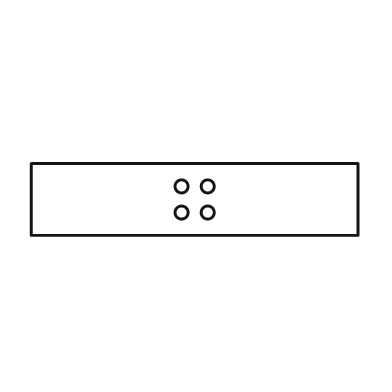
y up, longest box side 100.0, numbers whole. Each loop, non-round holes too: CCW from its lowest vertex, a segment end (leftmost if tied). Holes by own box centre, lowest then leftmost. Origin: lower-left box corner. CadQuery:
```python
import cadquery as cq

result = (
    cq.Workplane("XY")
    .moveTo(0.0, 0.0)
    .lineTo(100.0, 0.0)
    .lineTo(100.0, 22.0)
    .lineTo(0.0, 22.0)
    .close()
    .moveTo(46.0, 7.0)
    .circle(2.0)
    .moveTo(54.0, 7.0)
    .circle(2.0)
    .moveTo(46.0, 15.0)
    .circle(2.0)
    .moveTo(54.0, 15.0)
    .circle(2.0)
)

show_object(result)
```